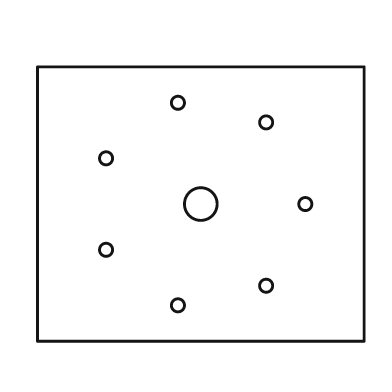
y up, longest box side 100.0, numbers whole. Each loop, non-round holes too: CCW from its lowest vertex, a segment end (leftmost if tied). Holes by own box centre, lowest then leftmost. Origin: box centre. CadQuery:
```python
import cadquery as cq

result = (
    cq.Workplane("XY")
    .moveTo(-50.0, -42.0)
    .lineTo(50.0, -42.0)
    .lineTo(50.0, 42.0)
    .lineTo(-50.0, 42.0)
    .close()
    .moveTo(-7.0, -31.0)
    .circle(2.0)
    .moveTo(20.0, -25.0)
    .circle(2.0)
    .moveTo(-29.0, -14.0)
    .circle(2.0)
    .moveTo(0.0, 0.0)
    .circle(5.0)
    .moveTo(32.0, 0.0)
    .circle(2.0)
    .moveTo(-29.0, 14.0)
    .circle(2.0)
    .moveTo(20.0, 25.0)
    .circle(2.0)
    .moveTo(-7.0, 31.0)
    .circle(2.0)
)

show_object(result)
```